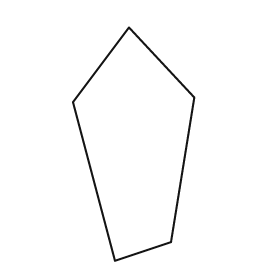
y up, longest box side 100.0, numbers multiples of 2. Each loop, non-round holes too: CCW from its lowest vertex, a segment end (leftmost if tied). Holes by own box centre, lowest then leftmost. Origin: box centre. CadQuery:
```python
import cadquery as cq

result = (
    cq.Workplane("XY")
    .moveTo(-8.0, -50.0)
    .lineTo(16.0, -42.0)
    .lineTo(26.0, 20.0)
    .lineTo(-2.0, 50.0)
    .lineTo(-26.0, 18.0)
    .close()
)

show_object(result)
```